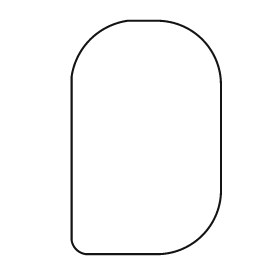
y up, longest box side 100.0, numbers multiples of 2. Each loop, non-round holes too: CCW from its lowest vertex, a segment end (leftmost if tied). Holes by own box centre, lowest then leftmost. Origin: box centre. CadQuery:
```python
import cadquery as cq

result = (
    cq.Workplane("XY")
    .moveTo(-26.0, -50.0)
    .lineTo(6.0, -50.0)
    .threePointArc((24.0, -42.0), (32.0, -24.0))
    .lineTo(32.0, 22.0)
    .threePointArc((24.0, 42.0), (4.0, 50.0))
    .lineTo(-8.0, 50.0)
    .threePointArc((-24.0, 42.0), (-32.0, 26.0))
    .lineTo(-32.0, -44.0)
    .threePointArc((-30.0, -48.0), (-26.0, -50.0))
    .close()
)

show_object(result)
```